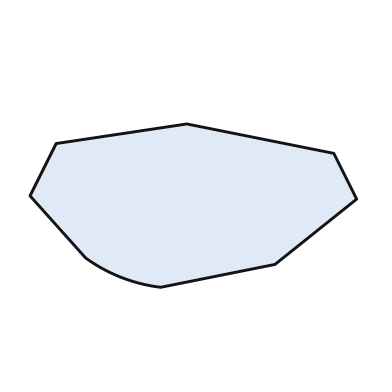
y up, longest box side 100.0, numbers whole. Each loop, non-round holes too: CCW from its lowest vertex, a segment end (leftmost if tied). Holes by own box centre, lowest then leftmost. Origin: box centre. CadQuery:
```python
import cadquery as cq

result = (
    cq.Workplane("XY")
    .moveTo(-10.0, -25.0)
    .lineTo(25.0, -18.0)
    .lineTo(50.0, 2.0)
    .lineTo(43.0, 16.0)
    .lineTo(-2.0, 25.0)
    .lineTo(-42.0, 19.0)
    .lineTo(-50.0, 3.0)
    .lineTo(-33.0, -16.0)
    .threePointArc((-22.0, -22.0), (-10.0, -25.0))
    .close()
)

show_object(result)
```